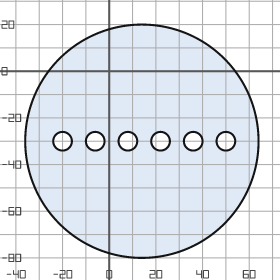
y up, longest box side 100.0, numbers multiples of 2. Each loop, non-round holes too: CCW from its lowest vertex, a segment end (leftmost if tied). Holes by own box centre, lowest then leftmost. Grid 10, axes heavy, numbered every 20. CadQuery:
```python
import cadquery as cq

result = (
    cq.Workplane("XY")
    .moveTo(14.0, -30.0)
    .circle(50.0)
    .moveTo(-20.0, -30.0)
    .circle(4.0)
    .moveTo(-6.0, -30.0)
    .circle(4.0)
    .moveTo(8.0, -30.0)
    .circle(4.0)
    .moveTo(22.0, -30.0)
    .circle(4.0)
    .moveTo(36.0, -30.0)
    .circle(4.0)
    .moveTo(50.0, -30.0)
    .circle(4.0)
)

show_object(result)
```